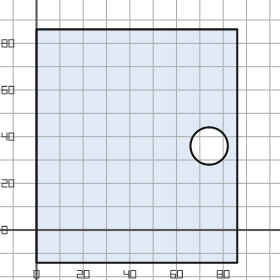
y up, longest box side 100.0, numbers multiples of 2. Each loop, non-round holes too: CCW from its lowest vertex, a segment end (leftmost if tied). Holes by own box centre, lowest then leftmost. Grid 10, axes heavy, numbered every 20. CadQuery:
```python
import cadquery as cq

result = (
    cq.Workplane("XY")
    .moveTo(0.0, -14.0)
    .lineTo(86.0, -14.0)
    .lineTo(86.0, 86.0)
    .lineTo(0.0, 86.0)
    .close()
    .moveTo(74.0, 36.0)
    .circle(8.0)
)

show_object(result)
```